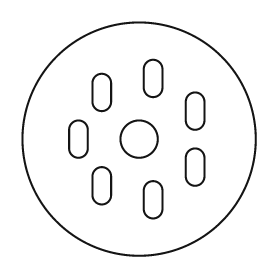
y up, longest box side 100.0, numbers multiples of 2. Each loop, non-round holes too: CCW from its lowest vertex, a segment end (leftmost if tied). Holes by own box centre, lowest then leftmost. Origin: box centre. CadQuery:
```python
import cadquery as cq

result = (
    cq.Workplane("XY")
    .moveTo(0.0, 0.0)
    .circle(50.0)
    .moveTo(2.0, -30.0)
    .threePointArc((6.0, -34.0), (10.0, -30.0))
    .lineTo(10.0, -22.0)
    .threePointArc((6.0, -18.0), (2.0, -22.0))
    .close()
    .moveTo(-20.0, -24.0)
    .threePointArc((-16.0, -28.0), (-12.0, -24.0))
    .lineTo(-12.0, -16.0)
    .threePointArc((-16.0, -12.0), (-20.0, -16.0))
    .close()
    .moveTo(20.0, -16.0)
    .threePointArc((24.0, -20.0), (28.0, -16.0))
    .lineTo(28.0, -8.0)
    .threePointArc((24.0, -4.0), (20.0, -8.0))
    .close()
    .moveTo(-30.0, -4.0)
    .threePointArc((-26.0, -8.0), (-22.0, -4.0))
    .lineTo(-22.0, 4.0)
    .threePointArc((-26.0, 8.0), (-30.0, 4.0))
    .close()
    .moveTo(0.0, 0.0)
    .circle(8.0)
    .moveTo(20.0, 8.0)
    .threePointArc((24.0, 4.0), (28.0, 8.0))
    .lineTo(28.0, 16.0)
    .threePointArc((24.0, 20.0), (20.0, 16.0))
    .close()
    .moveTo(-20.0, 16.0)
    .threePointArc((-16.0, 12.0), (-12.0, 16.0))
    .lineTo(-12.0, 24.0)
    .threePointArc((-16.0, 28.0), (-20.0, 24.0))
    .close()
    .moveTo(2.0, 22.0)
    .threePointArc((6.0, 18.0), (10.0, 22.0))
    .lineTo(10.0, 30.0)
    .threePointArc((6.0, 34.0), (2.0, 30.0))
    .close()
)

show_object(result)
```